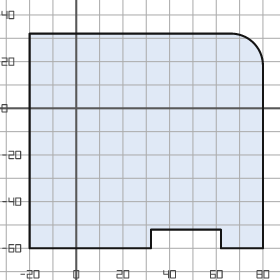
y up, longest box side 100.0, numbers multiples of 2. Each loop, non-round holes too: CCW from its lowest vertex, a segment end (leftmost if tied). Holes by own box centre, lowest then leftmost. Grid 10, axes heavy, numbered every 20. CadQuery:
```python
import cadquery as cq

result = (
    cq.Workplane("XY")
    .moveTo(-20.0, -60.0)
    .lineTo(32.0, -60.0)
    .lineTo(32.0, -52.0)
    .lineTo(62.0, -52.0)
    .lineTo(62.0, -60.0)
    .lineTo(80.0, -60.0)
    .lineTo(80.0, 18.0)
    .threePointArc((76.0, 28.0), (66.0, 32.0))
    .lineTo(-20.0, 32.0)
    .close()
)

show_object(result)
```